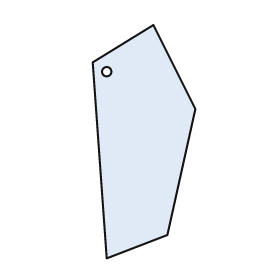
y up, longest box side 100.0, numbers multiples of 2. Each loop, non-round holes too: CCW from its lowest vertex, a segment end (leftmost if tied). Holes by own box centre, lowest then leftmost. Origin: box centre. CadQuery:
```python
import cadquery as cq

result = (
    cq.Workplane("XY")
    .moveTo(-16.0, -50.0)
    .lineTo(10.0, -40.0)
    .lineTo(22.0, 14.0)
    .lineTo(4.0, 50.0)
    .lineTo(-22.0, 34.0)
    .close()
    .moveTo(-16.0, 30.0)
    .circle(2.0)
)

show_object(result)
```